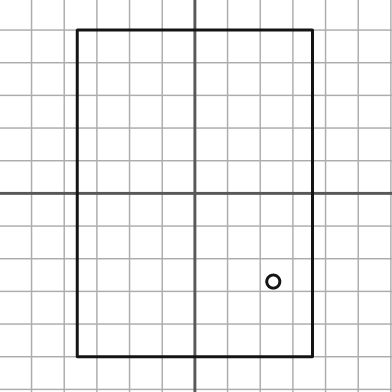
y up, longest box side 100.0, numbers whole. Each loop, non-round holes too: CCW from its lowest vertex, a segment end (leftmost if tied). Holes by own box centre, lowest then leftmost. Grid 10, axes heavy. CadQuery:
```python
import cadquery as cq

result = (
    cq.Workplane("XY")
    .moveTo(-36.0, -50.0)
    .lineTo(36.0, -50.0)
    .lineTo(36.0, 50.0)
    .lineTo(-36.0, 50.0)
    .close()
    .moveTo(24.0, -27.0)
    .circle(2.0)
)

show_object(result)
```